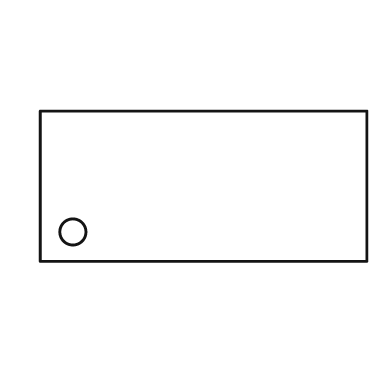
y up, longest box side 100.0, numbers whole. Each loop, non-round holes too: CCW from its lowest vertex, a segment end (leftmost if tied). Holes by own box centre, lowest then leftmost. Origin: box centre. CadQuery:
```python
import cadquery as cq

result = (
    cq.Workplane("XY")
    .moveTo(-50.0, -23.0)
    .lineTo(50.0, -23.0)
    .lineTo(50.0, 23.0)
    .lineTo(-50.0, 23.0)
    .close()
    .moveTo(-40.0, -14.0)
    .circle(4.0)
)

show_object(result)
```